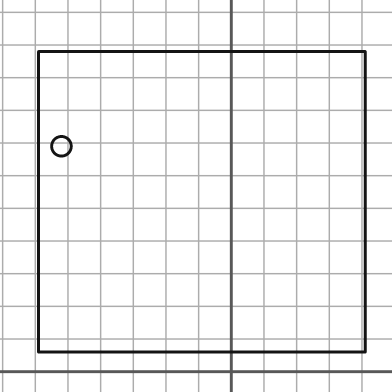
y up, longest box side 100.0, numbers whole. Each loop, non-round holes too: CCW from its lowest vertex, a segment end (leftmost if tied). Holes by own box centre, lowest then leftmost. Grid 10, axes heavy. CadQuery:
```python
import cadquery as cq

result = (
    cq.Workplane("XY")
    .moveTo(-59.0, 6.0)
    .lineTo(41.0, 6.0)
    .lineTo(41.0, 98.0)
    .lineTo(-59.0, 98.0)
    .close()
    .moveTo(-52.0, 69.0)
    .circle(3.0)
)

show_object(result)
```